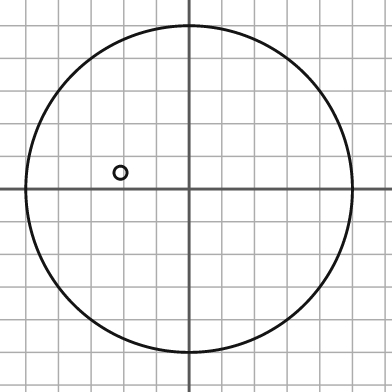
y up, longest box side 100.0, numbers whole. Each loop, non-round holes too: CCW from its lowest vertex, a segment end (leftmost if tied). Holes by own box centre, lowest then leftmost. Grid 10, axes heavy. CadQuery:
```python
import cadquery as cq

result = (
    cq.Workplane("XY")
    .moveTo(0.0, 0.0)
    .circle(50.0)
    .moveTo(-21.0, 5.0)
    .circle(2.0)
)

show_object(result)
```